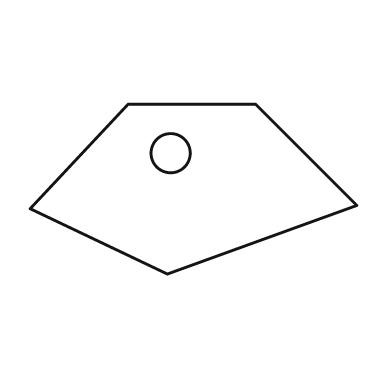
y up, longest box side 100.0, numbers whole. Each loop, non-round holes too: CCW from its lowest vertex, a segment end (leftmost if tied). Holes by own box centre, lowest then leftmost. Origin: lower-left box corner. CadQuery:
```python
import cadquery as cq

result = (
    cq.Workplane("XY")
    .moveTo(42.0, 0.0)
    .lineTo(100.0, 21.0)
    .lineTo(69.0, 52.0)
    .lineTo(30.0, 52.0)
    .lineTo(0.0, 20.0)
    .close()
    .moveTo(43.0, 37.0)
    .circle(6.0)
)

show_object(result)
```